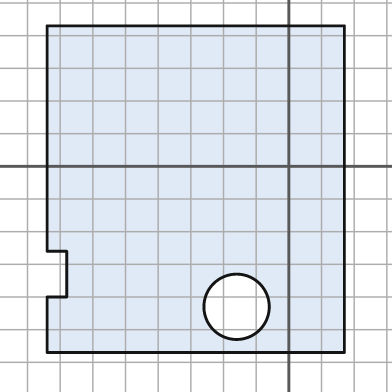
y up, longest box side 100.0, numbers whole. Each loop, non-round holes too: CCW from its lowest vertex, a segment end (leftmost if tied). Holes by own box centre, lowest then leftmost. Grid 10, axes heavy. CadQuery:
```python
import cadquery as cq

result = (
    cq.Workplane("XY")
    .moveTo(-74.0, -57.0)
    .lineTo(17.0, -57.0)
    .lineTo(17.0, 43.0)
    .lineTo(-74.0, 43.0)
    .lineTo(-74.0, -26.0)
    .lineTo(-68.0, -26.0)
    .lineTo(-68.0, -40.0)
    .lineTo(-74.0, -40.0)
    .close()
    .moveTo(-16.0, -43.0)
    .circle(10.0)
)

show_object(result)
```